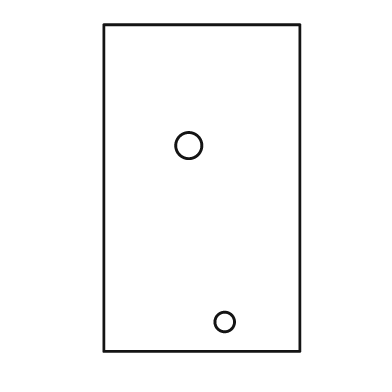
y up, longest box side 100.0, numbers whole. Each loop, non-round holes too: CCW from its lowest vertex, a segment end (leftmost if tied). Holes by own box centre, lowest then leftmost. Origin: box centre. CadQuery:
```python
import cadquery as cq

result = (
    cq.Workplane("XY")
    .moveTo(-30.0, -50.0)
    .lineTo(30.0, -50.0)
    .lineTo(30.0, 50.0)
    .lineTo(-30.0, 50.0)
    .close()
    .moveTo(7.0, -41.0)
    .circle(3.0)
    .moveTo(-4.0, 13.0)
    .circle(4.0)
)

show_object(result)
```